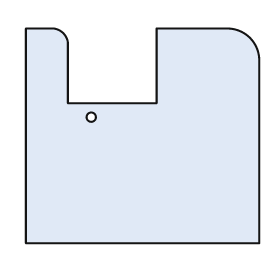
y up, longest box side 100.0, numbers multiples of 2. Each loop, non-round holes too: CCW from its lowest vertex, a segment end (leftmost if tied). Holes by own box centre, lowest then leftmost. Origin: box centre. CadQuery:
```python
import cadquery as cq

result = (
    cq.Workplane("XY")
    .moveTo(-50.0, -46.0)
    .lineTo(50.0, -46.0)
    .lineTo(50.0, 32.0)
    .threePointArc((46.0, 42.0), (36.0, 46.0))
    .lineTo(6.0, 46.0)
    .lineTo(6.0, 14.0)
    .lineTo(-32.0, 14.0)
    .lineTo(-32.0, 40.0)
    .threePointArc((-34.0, 44.0), (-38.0, 46.0))
    .lineTo(-50.0, 46.0)
    .close()
    .moveTo(-22.0, 8.0)
    .circle(2.0)
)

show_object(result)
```